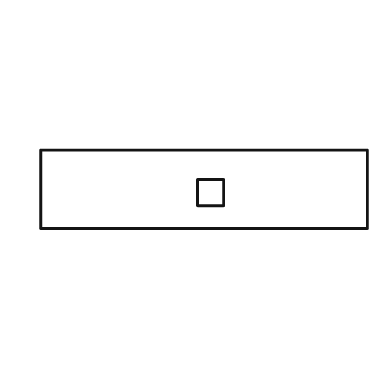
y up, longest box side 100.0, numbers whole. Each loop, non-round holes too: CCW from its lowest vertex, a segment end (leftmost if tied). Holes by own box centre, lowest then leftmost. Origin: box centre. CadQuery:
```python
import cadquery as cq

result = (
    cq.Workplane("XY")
    .moveTo(-50.0, -12.0)
    .lineTo(50.0, -12.0)
    .lineTo(50.0, 12.0)
    .lineTo(-50.0, 12.0)
    .close()
    .moveTo(-2.0, -5.0)
    .lineTo(6.0, -5.0)
    .lineTo(6.0, 3.0)
    .lineTo(-2.0, 3.0)
    .close()
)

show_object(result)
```